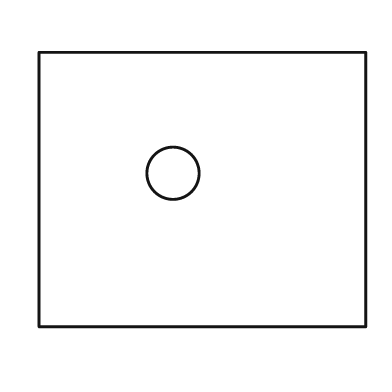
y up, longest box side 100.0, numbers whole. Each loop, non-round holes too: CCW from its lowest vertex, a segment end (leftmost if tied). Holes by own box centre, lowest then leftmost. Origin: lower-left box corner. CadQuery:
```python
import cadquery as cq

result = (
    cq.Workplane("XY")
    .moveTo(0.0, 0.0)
    .lineTo(100.0, 0.0)
    .lineTo(100.0, 84.0)
    .lineTo(0.0, 84.0)
    .close()
    .moveTo(41.0, 47.0)
    .circle(8.0)
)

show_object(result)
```